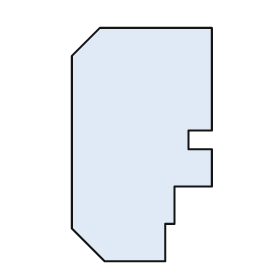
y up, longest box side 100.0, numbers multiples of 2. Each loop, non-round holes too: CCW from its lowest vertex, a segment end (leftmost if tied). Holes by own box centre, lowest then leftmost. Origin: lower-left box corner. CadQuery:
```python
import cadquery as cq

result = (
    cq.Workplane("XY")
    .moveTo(14.0, 0.0)
    .lineTo(40.0, 0.0)
    .lineTo(40.0, 16.0)
    .lineTo(44.0, 16.0)
    .lineTo(44.0, 32.0)
    .lineTo(60.0, 32.0)
    .lineTo(60.0, 48.0)
    .lineTo(50.0, 48.0)
    .lineTo(50.0, 56.0)
    .lineTo(60.0, 56.0)
    .lineTo(60.0, 100.0)
    .lineTo(12.0, 100.0)
    .lineTo(0.0, 88.0)
    .lineTo(0.0, 14.0)
    .close()
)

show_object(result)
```